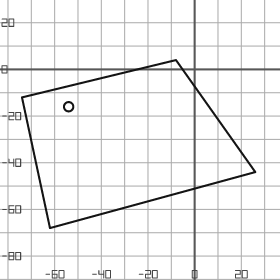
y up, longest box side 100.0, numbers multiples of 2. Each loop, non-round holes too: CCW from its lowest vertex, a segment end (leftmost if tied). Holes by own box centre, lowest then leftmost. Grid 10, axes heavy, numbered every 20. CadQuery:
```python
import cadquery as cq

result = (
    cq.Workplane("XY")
    .moveTo(-62.0, -68.0)
    .lineTo(26.0, -44.0)
    .lineTo(-8.0, 4.0)
    .lineTo(-74.0, -12.0)
    .close()
    .moveTo(-54.0, -16.0)
    .circle(2.0)
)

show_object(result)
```